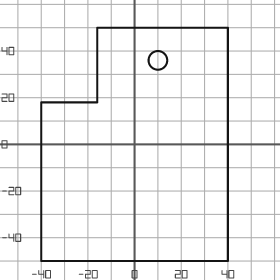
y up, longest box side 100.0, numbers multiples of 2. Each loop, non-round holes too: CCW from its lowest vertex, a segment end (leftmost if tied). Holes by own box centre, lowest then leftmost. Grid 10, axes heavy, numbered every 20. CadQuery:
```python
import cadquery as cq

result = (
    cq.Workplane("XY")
    .moveTo(-40.0, -50.0)
    .lineTo(40.0, -50.0)
    .lineTo(40.0, 50.0)
    .lineTo(-16.0, 50.0)
    .lineTo(-16.0, 18.0)
    .lineTo(-40.0, 18.0)
    .close()
    .moveTo(10.0, 36.0)
    .circle(4.0)
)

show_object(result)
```